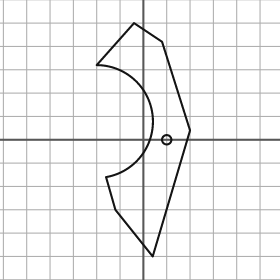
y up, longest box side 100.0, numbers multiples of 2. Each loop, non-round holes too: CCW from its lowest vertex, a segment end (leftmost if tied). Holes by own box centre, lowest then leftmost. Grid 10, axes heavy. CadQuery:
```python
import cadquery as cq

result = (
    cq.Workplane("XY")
    .moveTo(4.0, -50.0)
    .lineTo(20.0, 4.0)
    .lineTo(8.0, 42.0)
    .lineTo(-4.0, 50.0)
    .lineTo(-20.0, 32.0)
    .threePointArc((4.0, 10.0), (-16.0, -16.0))
    .lineTo(-12.0, -30.0)
    .close()
    .moveTo(10.0, 0.0)
    .circle(2.0)
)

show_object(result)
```